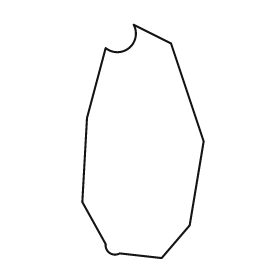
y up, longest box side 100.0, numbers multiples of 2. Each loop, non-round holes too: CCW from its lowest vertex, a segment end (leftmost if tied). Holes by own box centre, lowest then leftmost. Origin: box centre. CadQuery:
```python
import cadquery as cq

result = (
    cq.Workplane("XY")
    .moveTo(8.0, -50.0)
    .lineTo(20.0, -36.0)
    .lineTo(26.0, 0.0)
    .lineTo(12.0, 42.0)
    .lineTo(-4.0, 50.0)
    .threePointArc((-6.0, 40.0), (-16.0, 40.0))
    .lineTo(-24.0, 10.0)
    .lineTo(-26.0, -26.0)
    .lineTo(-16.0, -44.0)
    .threePointArc((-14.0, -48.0), (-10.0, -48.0))
    .close()
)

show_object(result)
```